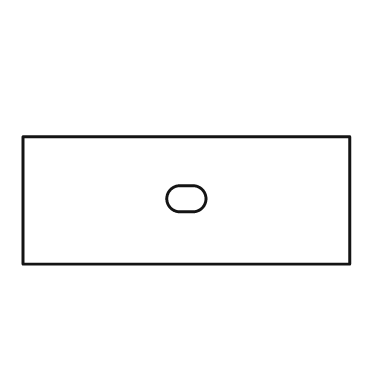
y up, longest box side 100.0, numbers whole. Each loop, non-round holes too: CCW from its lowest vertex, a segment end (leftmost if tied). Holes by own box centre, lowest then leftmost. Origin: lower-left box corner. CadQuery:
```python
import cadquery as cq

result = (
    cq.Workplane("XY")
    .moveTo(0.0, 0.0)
    .lineTo(100.0, 0.0)
    .lineTo(100.0, 39.0)
    .lineTo(0.0, 39.0)
    .close()
    .moveTo(48.0, 16.0)
    .lineTo(52.0, 16.0)
    .threePointArc((56.0, 20.0), (52.0, 24.0))
    .lineTo(48.0, 24.0)
    .threePointArc((44.0, 20.0), (48.0, 16.0))
    .close()
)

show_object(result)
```